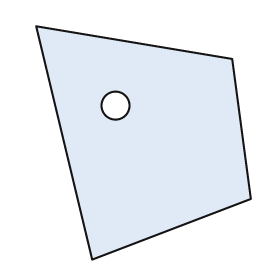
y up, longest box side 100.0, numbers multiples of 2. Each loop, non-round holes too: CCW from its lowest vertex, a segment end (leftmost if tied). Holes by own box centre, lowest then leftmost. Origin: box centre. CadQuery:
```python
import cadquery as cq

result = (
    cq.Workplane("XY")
    .moveTo(-22.0, -50.0)
    .lineTo(46.0, -24.0)
    .lineTo(38.0, 36.0)
    .lineTo(-46.0, 50.0)
    .close()
    .moveTo(-12.0, 16.0)
    .circle(6.0)
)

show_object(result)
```